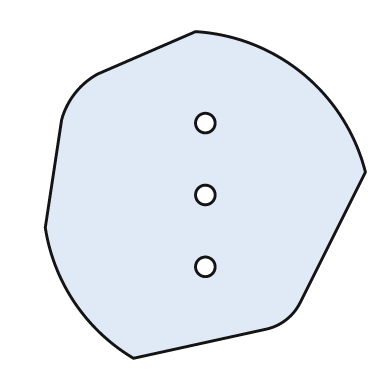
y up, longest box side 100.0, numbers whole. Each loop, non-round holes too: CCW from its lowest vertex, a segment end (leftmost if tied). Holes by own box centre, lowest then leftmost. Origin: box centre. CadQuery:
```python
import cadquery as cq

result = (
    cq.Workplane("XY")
    .moveTo(-22.0, -50.0)
    .lineTo(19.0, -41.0)
    .threePointArc((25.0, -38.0), (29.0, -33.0))
    .lineTo(49.0, 7.0)
    .threePointArc((30.0, 37.0), (-3.0, 50.0))
    .lineTo(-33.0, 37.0)
    .threePointArc((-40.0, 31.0), (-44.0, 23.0))
    .lineTo(-49.0, -10.0)
    .threePointArc((-40.0, -33.0), (-22.0, -50.0))
    .close()
    .moveTo(0.0, -22.0)
    .circle(3.0)
    .moveTo(0.0, 0.0)
    .circle(3.0)
    .moveTo(0.0, 22.0)
    .circle(3.0)
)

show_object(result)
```